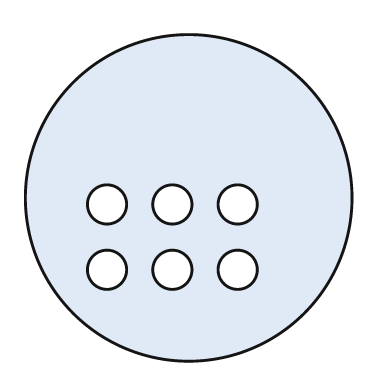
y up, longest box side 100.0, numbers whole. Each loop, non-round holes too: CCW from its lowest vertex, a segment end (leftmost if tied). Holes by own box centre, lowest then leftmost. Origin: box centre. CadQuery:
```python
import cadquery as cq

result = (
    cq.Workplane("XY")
    .moveTo(0.0, 0.0)
    .circle(50.0)
    .moveTo(-25.0, -22.0)
    .circle(6.0)
    .moveTo(-5.0, -22.0)
    .circle(6.0)
    .moveTo(15.0, -22.0)
    .circle(6.0)
    .moveTo(-25.0, -2.0)
    .circle(6.0)
    .moveTo(-5.0, -2.0)
    .circle(6.0)
    .moveTo(15.0, -2.0)
    .circle(6.0)
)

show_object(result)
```